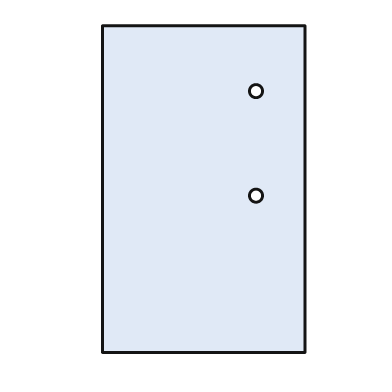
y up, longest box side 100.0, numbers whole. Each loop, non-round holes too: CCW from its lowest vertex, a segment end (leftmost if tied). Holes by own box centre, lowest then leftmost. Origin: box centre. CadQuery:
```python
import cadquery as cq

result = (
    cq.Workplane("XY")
    .moveTo(-31.0, -50.0)
    .lineTo(31.0, -50.0)
    .lineTo(31.0, 50.0)
    .lineTo(-31.0, 50.0)
    .close()
    .moveTo(16.0, -2.0)
    .circle(2.0)
    .moveTo(16.0, 30.0)
    .circle(2.0)
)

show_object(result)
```